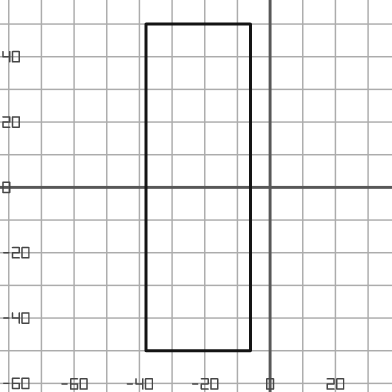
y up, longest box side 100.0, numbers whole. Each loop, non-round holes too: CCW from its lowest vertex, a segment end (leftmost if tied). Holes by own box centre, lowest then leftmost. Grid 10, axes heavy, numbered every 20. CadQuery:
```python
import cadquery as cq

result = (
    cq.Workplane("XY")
    .moveTo(-38.0, -50.0)
    .lineTo(-6.0, -50.0)
    .lineTo(-6.0, 50.0)
    .lineTo(-38.0, 50.0)
    .close()
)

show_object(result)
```